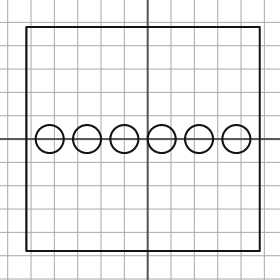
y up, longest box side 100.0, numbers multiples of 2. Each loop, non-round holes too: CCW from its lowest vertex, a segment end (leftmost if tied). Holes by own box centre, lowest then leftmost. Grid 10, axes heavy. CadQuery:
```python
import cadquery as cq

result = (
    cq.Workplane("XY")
    .moveTo(-52.0, -48.0)
    .lineTo(48.0, -48.0)
    .lineTo(48.0, 48.0)
    .lineTo(-52.0, 48.0)
    .close()
    .moveTo(-42.0, 0.0)
    .circle(6.0)
    .moveTo(-26.0, 0.0)
    .circle(6.0)
    .moveTo(-10.0, 0.0)
    .circle(6.0)
    .moveTo(6.0, 0.0)
    .circle(6.0)
    .moveTo(22.0, 0.0)
    .circle(6.0)
    .moveTo(38.0, 0.0)
    .circle(6.0)
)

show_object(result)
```